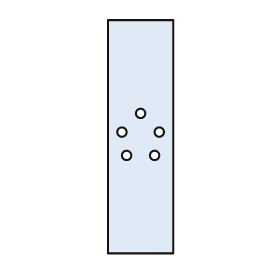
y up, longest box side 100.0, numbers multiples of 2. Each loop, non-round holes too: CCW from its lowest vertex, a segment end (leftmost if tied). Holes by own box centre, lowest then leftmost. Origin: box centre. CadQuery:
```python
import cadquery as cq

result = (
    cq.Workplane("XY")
    .moveTo(-14.0, -50.0)
    .lineTo(14.0, -50.0)
    .lineTo(14.0, 50.0)
    .lineTo(-14.0, 50.0)
    .close()
    .moveTo(-6.0, -8.0)
    .circle(2.0)
    .moveTo(6.0, -8.0)
    .circle(2.0)
    .moveTo(-8.0, 2.0)
    .circle(2.0)
    .moveTo(8.0, 2.0)
    .circle(2.0)
    .moveTo(0.0, 10.0)
    .circle(2.0)
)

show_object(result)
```